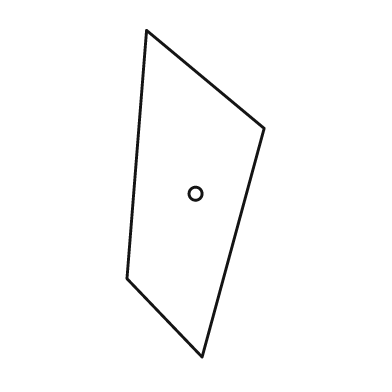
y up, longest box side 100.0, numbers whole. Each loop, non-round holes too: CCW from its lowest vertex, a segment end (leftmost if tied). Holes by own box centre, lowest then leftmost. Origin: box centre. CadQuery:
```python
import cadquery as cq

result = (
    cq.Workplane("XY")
    .moveTo(2.0, -50.0)
    .lineTo(21.0, 20.0)
    .lineTo(-15.0, 50.0)
    .lineTo(-21.0, -26.0)
    .close()
    .moveTo(0.0, 0.0)
    .circle(2.0)
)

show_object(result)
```